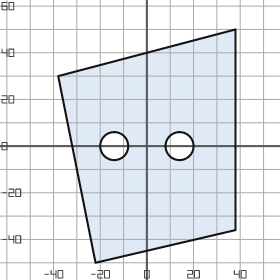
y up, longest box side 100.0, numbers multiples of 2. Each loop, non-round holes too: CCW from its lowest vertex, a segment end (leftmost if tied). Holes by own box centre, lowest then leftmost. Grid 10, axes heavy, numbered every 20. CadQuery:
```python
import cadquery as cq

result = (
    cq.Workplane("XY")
    .moveTo(-22.0, -50.0)
    .lineTo(38.0, -36.0)
    .lineTo(38.0, 50.0)
    .lineTo(-38.0, 30.0)
    .close()
    .moveTo(-14.0, 0.0)
    .circle(6.0)
    .moveTo(14.0, 0.0)
    .circle(6.0)
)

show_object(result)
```